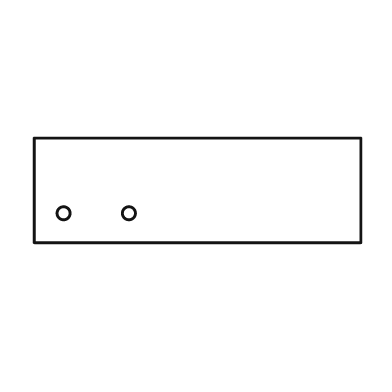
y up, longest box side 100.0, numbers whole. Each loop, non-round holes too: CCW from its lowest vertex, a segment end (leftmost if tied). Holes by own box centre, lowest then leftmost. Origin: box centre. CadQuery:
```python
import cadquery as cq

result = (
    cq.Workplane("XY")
    .moveTo(-50.0, -16.0)
    .lineTo(50.0, -16.0)
    .lineTo(50.0, 16.0)
    .lineTo(-50.0, 16.0)
    .close()
    .moveTo(-41.0, -7.0)
    .circle(2.0)
    .moveTo(-21.0, -7.0)
    .circle(2.0)
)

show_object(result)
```